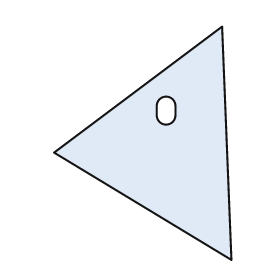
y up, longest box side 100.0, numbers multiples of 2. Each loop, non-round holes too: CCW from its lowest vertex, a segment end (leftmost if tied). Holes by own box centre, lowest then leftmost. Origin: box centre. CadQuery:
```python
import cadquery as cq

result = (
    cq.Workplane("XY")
    .moveTo(38.0, -50.0)
    .lineTo(34.0, 50.0)
    .lineTo(-38.0, -4.0)
    .close()
    .moveTo(6.0, 12.0)
    .threePointArc((10.0, 8.0), (14.0, 12.0))
    .lineTo(14.0, 16.0)
    .threePointArc((10.0, 20.0), (6.0, 16.0))
    .close()
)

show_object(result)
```